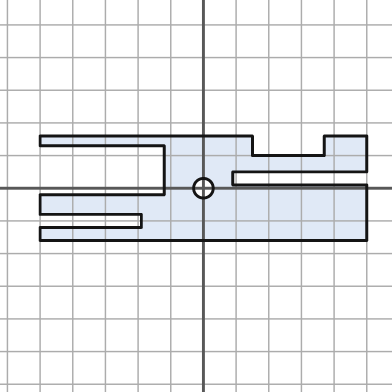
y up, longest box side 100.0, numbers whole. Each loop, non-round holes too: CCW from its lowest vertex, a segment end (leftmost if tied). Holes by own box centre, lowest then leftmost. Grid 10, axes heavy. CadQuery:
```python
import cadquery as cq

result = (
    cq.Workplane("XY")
    .moveTo(-50.0, -16.0)
    .lineTo(50.0, -16.0)
    .lineTo(50.0, 1.0)
    .lineTo(9.0, 1.0)
    .lineTo(9.0, 5.0)
    .lineTo(50.0, 5.0)
    .lineTo(50.0, 16.0)
    .lineTo(37.0, 16.0)
    .lineTo(37.0, 10.0)
    .lineTo(15.0, 10.0)
    .lineTo(15.0, 16.0)
    .lineTo(-50.0, 16.0)
    .lineTo(-50.0, 13.0)
    .lineTo(-12.0, 13.0)
    .lineTo(-12.0, -2.0)
    .lineTo(-50.0, -2.0)
    .lineTo(-50.0, -8.0)
    .lineTo(-19.0, -8.0)
    .lineTo(-19.0, -12.0)
    .lineTo(-50.0, -12.0)
    .close()
    .moveTo(0.0, 0.0)
    .circle(3.0)
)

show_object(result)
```